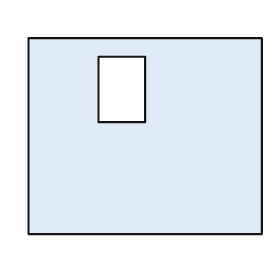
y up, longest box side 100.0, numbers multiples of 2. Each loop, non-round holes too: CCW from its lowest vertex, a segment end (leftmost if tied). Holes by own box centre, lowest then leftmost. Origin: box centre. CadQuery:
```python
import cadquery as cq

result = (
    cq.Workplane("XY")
    .moveTo(-50.0, -42.0)
    .lineTo(50.0, -42.0)
    .lineTo(50.0, 42.0)
    .lineTo(-50.0, 42.0)
    .close()
    .moveTo(-20.0, 6.0)
    .lineTo(0.0, 6.0)
    .lineTo(0.0, 34.0)
    .lineTo(-20.0, 34.0)
    .close()
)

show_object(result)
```